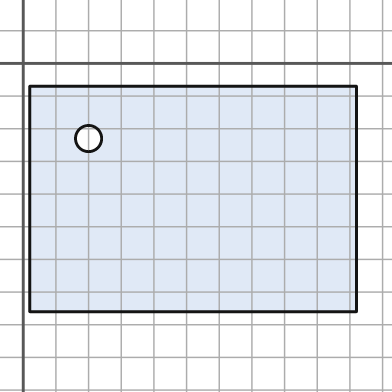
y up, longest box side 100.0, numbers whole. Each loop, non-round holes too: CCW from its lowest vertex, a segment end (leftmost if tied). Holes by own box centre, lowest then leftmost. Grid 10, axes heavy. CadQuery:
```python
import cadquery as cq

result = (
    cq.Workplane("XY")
    .moveTo(2.0, -76.0)
    .lineTo(102.0, -76.0)
    .lineTo(102.0, -7.0)
    .lineTo(2.0, -7.0)
    .close()
    .moveTo(20.0, -23.0)
    .circle(4.0)
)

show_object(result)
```